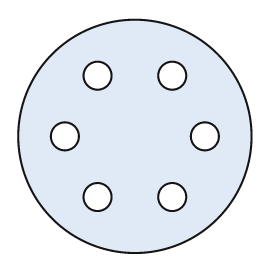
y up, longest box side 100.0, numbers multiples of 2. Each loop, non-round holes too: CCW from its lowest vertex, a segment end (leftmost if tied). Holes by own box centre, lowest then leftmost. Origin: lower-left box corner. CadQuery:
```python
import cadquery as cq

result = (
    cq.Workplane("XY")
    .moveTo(50.0, 50.0)
    .circle(50.0)
    .moveTo(34.0, 24.0)
    .circle(6.0)
    .moveTo(66.0, 24.0)
    .circle(6.0)
    .moveTo(20.0, 50.0)
    .circle(6.0)
    .moveTo(80.0, 50.0)
    .circle(6.0)
    .moveTo(34.0, 76.0)
    .circle(6.0)
    .moveTo(66.0, 76.0)
    .circle(6.0)
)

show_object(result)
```